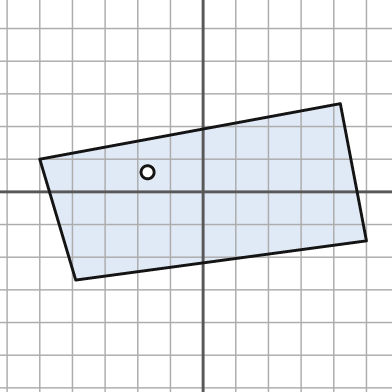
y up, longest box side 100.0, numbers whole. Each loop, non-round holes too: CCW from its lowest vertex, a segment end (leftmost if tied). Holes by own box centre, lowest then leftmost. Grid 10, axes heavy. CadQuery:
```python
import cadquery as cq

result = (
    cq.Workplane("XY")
    .moveTo(-39.0, -27.0)
    .lineTo(50.0, -15.0)
    .lineTo(42.0, 27.0)
    .lineTo(-50.0, 10.0)
    .close()
    .moveTo(-17.0, 6.0)
    .circle(2.0)
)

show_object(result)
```